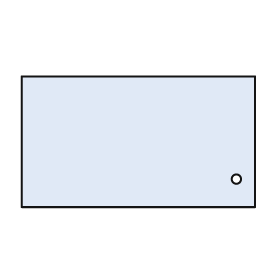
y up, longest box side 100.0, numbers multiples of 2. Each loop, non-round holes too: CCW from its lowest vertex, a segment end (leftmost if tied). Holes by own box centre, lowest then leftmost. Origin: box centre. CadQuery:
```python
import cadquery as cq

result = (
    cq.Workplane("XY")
    .moveTo(-50.0, -28.0)
    .lineTo(50.0, -28.0)
    .lineTo(50.0, 28.0)
    .lineTo(-50.0, 28.0)
    .close()
    .moveTo(42.0, -16.0)
    .circle(2.0)
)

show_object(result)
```